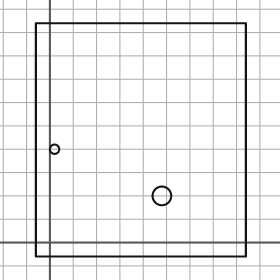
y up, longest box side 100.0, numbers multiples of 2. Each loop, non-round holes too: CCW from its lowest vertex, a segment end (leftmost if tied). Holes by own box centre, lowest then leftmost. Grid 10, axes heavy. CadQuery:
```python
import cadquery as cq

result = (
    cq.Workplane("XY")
    .moveTo(-6.0, -6.0)
    .lineTo(84.0, -6.0)
    .lineTo(84.0, 94.0)
    .lineTo(-6.0, 94.0)
    .close()
    .moveTo(48.0, 20.0)
    .circle(4.0)
    .moveTo(2.0, 40.0)
    .circle(2.0)
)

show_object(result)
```